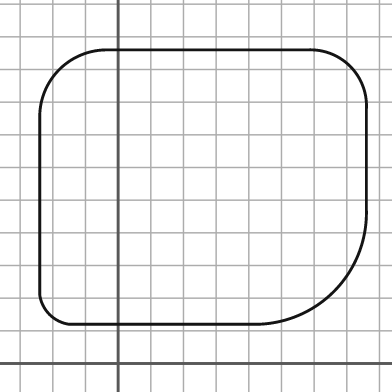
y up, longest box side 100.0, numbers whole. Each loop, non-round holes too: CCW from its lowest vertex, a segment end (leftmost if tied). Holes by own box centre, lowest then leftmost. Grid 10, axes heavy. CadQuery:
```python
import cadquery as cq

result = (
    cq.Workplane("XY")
    .moveTo(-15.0, 12.0)
    .lineTo(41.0, 12.0)
    .threePointArc((66.0, 22.0), (76.0, 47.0))
    .lineTo(76.0, 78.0)
    .threePointArc((71.0, 91.0), (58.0, 96.0))
    .lineTo(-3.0, 96.0)
    .threePointArc((-18.0, 90.0), (-24.0, 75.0))
    .lineTo(-24.0, 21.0)
    .threePointArc((-21.0, 15.0), (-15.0, 12.0))
    .close()
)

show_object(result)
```